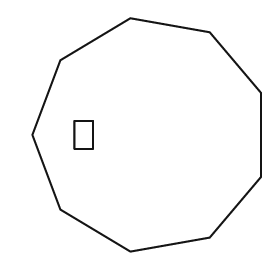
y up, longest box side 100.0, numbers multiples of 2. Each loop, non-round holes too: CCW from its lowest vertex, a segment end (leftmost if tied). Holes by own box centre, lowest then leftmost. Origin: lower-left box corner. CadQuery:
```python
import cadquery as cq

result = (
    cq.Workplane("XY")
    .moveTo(42.0, 0.0)
    .lineTo(76.0, 6.0)
    .lineTo(98.0, 32.0)
    .lineTo(98.0, 68.0)
    .lineTo(76.0, 94.0)
    .lineTo(42.0, 100.0)
    .lineTo(12.0, 82.0)
    .lineTo(0.0, 50.0)
    .lineTo(12.0, 18.0)
    .close()
    .moveTo(18.0, 44.0)
    .lineTo(26.0, 44.0)
    .lineTo(26.0, 56.0)
    .lineTo(18.0, 56.0)
    .close()
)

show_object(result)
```